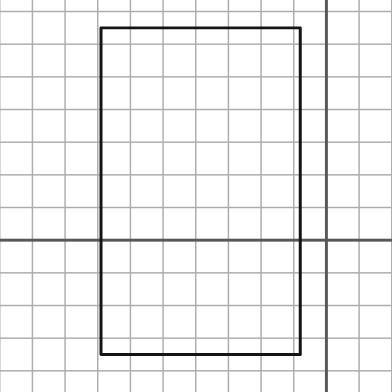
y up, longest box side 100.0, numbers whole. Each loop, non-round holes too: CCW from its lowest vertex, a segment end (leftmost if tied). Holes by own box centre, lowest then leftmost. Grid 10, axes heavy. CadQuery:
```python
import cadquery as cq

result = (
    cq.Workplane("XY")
    .moveTo(-69.0, -35.0)
    .lineTo(-8.0, -35.0)
    .lineTo(-8.0, 65.0)
    .lineTo(-69.0, 65.0)
    .close()
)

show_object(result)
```